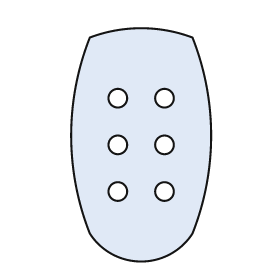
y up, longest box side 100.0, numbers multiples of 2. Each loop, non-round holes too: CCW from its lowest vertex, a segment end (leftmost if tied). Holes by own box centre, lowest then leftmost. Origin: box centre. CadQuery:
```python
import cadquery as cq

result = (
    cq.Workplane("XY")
    .moveTo(-22.0, -38.0)
    .threePointArc((0.0, -50.0), (22.0, -38.0))
    .threePointArc((30.0, 4.0), (22.0, 46.0))
    .threePointArc((0.0, 50.0), (-22.0, 46.0))
    .threePointArc((-30.0, 4.0), (-22.0, -38.0))
    .close()
    .moveTo(-10.0, -20.0)
    .circle(4.0)
    .moveTo(10.0, -20.0)
    .circle(4.0)
    .moveTo(-10.0, 0.0)
    .circle(4.0)
    .moveTo(10.0, 0.0)
    .circle(4.0)
    .moveTo(-10.0, 20.0)
    .circle(4.0)
    .moveTo(10.0, 20.0)
    .circle(4.0)
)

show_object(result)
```